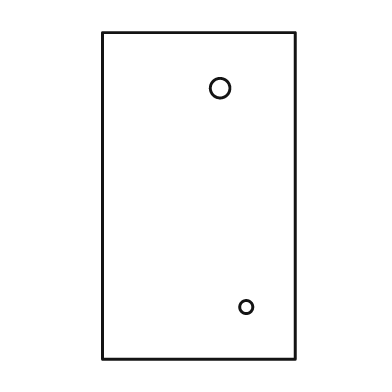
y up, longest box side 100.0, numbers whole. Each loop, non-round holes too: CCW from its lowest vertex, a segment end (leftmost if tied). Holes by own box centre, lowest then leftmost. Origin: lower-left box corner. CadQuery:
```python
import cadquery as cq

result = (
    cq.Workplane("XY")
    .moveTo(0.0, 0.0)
    .lineTo(59.0, 0.0)
    .lineTo(59.0, 100.0)
    .lineTo(0.0, 100.0)
    .close()
    .moveTo(44.0, 16.0)
    .circle(2.0)
    .moveTo(36.0, 83.0)
    .circle(3.0)
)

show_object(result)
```